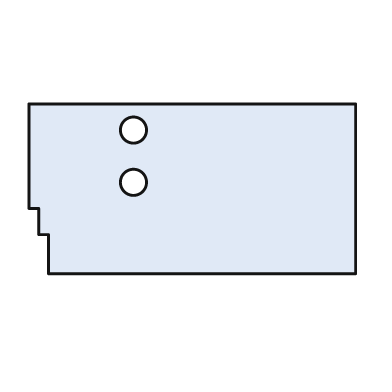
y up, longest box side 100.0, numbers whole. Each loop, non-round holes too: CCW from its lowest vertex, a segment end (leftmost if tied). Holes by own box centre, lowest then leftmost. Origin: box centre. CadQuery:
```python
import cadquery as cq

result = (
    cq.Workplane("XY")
    .moveTo(-44.0, -26.0)
    .lineTo(50.0, -26.0)
    .lineTo(50.0, 26.0)
    .lineTo(-50.0, 26.0)
    .lineTo(-50.0, -6.0)
    .lineTo(-47.0, -6.0)
    .lineTo(-47.0, -14.0)
    .lineTo(-44.0, -14.0)
    .close()
    .moveTo(-18.0, 2.0)
    .circle(4.0)
    .moveTo(-18.0, 18.0)
    .circle(4.0)
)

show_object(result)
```